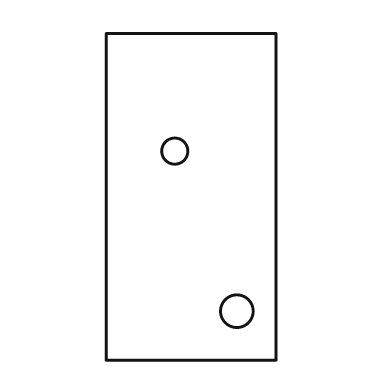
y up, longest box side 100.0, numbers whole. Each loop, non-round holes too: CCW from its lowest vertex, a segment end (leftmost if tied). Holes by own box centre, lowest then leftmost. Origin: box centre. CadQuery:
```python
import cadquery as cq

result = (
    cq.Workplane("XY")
    .moveTo(-26.0, -50.0)
    .lineTo(26.0, -50.0)
    .lineTo(26.0, 50.0)
    .lineTo(-26.0, 50.0)
    .close()
    .moveTo(14.0, -35.0)
    .circle(5.0)
    .moveTo(-5.0, 14.0)
    .circle(4.0)
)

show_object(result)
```